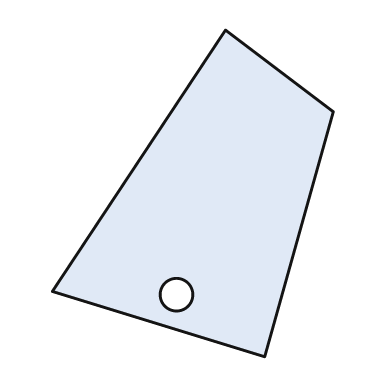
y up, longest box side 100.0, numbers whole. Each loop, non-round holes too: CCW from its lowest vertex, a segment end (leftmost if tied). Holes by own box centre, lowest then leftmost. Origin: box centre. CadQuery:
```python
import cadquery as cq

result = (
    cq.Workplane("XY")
    .moveTo(22.0, -50.0)
    .lineTo(43.0, 25.0)
    .lineTo(10.0, 50.0)
    .lineTo(-43.0, -30.0)
    .close()
    .moveTo(-5.0, -31.0)
    .circle(5.0)
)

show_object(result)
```